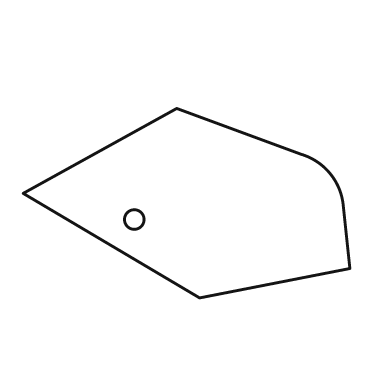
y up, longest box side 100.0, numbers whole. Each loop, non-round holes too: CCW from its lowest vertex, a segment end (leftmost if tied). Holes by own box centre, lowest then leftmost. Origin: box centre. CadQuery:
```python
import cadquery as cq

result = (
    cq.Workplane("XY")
    .moveTo(4.0, -29.0)
    .lineTo(50.0, -20.0)
    .lineTo(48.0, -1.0)
    .threePointArc((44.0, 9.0), (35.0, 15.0))
    .lineTo(-3.0, 29.0)
    .lineTo(-50.0, 3.0)
    .close()
    .moveTo(-16.0, -5.0)
    .circle(3.0)
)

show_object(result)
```